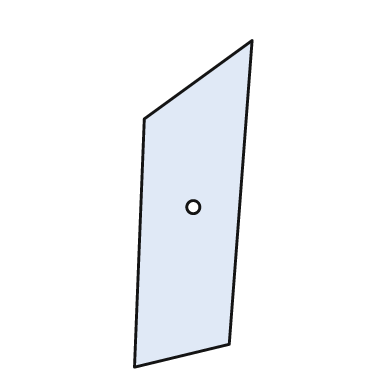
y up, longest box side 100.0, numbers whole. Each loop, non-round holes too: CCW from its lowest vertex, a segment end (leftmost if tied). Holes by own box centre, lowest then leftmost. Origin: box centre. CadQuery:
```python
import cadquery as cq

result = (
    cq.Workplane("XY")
    .moveTo(-18.0, -50.0)
    .lineTo(11.0, -43.0)
    .lineTo(18.0, 50.0)
    .lineTo(-15.0, 26.0)
    .close()
    .moveTo(0.0, -1.0)
    .circle(2.0)
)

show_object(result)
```